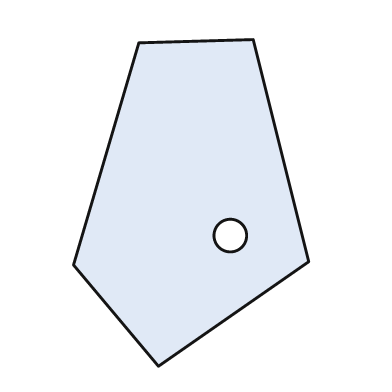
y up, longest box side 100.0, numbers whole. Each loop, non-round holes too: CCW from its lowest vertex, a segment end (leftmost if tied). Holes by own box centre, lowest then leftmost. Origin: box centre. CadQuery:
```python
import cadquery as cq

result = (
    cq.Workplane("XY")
    .moveTo(-10.0, -50.0)
    .lineTo(36.0, -18.0)
    .lineTo(19.0, 50.0)
    .lineTo(-16.0, 49.0)
    .lineTo(-36.0, -19.0)
    .close()
    .moveTo(12.0, -10.0)
    .circle(5.0)
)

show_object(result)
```